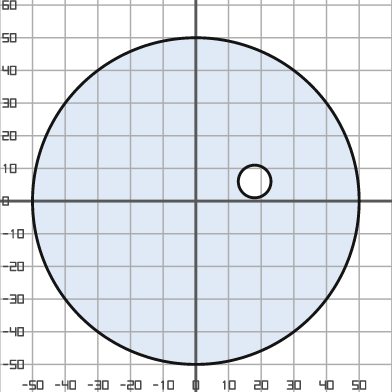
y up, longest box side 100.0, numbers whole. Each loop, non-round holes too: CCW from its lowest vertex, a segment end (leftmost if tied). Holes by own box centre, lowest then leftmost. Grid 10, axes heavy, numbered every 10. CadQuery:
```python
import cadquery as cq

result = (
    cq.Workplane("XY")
    .moveTo(0.0, 0.0)
    .circle(50.0)
    .moveTo(18.0, 6.0)
    .circle(5.0)
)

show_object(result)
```